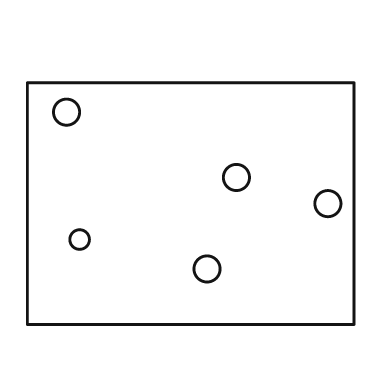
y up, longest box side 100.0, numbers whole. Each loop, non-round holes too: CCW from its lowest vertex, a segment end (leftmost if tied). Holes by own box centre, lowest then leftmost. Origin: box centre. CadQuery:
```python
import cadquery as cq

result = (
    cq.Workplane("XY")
    .moveTo(-50.0, -37.0)
    .lineTo(50.0, -37.0)
    .lineTo(50.0, 37.0)
    .lineTo(-50.0, 37.0)
    .close()
    .moveTo(5.0, -20.0)
    .circle(4.0)
    .moveTo(-34.0, -11.0)
    .circle(3.0)
    .moveTo(42.0, 0.0)
    .circle(4.0)
    .moveTo(14.0, 8.0)
    .circle(4.0)
    .moveTo(-38.0, 28.0)
    .circle(4.0)
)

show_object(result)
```